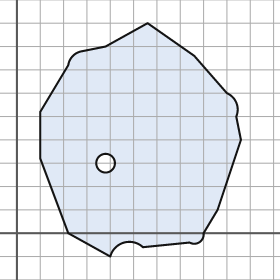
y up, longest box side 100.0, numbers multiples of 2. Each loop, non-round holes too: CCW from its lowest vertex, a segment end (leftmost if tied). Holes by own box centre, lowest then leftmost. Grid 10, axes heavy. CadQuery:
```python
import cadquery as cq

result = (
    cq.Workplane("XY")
    .moveTo(40.0, -10.0)
    .threePointArc((46.0, -4.0), (54.0, -6.0))
    .lineTo(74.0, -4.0)
    .threePointArc((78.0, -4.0), (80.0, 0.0))
    .lineTo(86.0, 10.0)
    .lineTo(96.0, 40.0)
    .lineTo(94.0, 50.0)
    .threePointArc((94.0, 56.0), (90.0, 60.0))
    .lineTo(76.0, 76.0)
    .lineTo(56.0, 90.0)
    .lineTo(38.0, 80.0)
    .lineTo(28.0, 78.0)
    .threePointArc((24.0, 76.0), (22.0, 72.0))
    .lineTo(10.0, 52.0)
    .lineTo(10.0, 32.0)
    .lineTo(22.0, 0.0)
    .close()
    .moveTo(38.0, 30.0)
    .circle(4.0)
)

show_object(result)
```